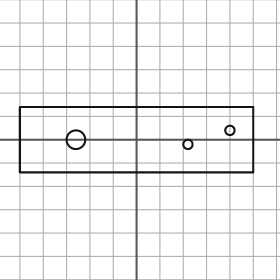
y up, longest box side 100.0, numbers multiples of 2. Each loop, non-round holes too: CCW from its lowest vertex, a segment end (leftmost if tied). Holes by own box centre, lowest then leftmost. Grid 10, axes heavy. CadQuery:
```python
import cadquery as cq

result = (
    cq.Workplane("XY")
    .moveTo(-50.0, -14.0)
    .lineTo(50.0, -14.0)
    .lineTo(50.0, 14.0)
    .lineTo(-50.0, 14.0)
    .close()
    .moveTo(22.0, -2.0)
    .circle(2.0)
    .moveTo(-26.0, 0.0)
    .circle(4.0)
    .moveTo(40.0, 4.0)
    .circle(2.0)
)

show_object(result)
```